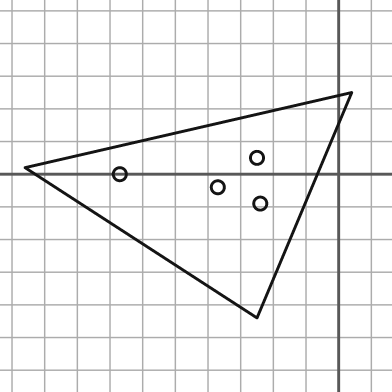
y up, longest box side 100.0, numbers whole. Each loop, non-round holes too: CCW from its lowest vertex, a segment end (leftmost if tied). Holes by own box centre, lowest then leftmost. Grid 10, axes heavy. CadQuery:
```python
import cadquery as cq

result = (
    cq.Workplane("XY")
    .moveTo(-25.0, -44.0)
    .lineTo(4.0, 25.0)
    .lineTo(-96.0, 2.0)
    .close()
    .moveTo(-24.0, -9.0)
    .circle(2.0)
    .moveTo(-37.0, -4.0)
    .circle(2.0)
    .moveTo(-67.0, 0.0)
    .circle(2.0)
    .moveTo(-25.0, 5.0)
    .circle(2.0)
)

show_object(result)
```